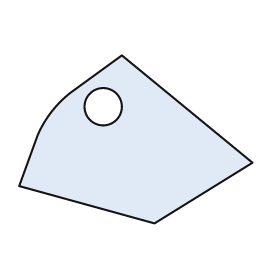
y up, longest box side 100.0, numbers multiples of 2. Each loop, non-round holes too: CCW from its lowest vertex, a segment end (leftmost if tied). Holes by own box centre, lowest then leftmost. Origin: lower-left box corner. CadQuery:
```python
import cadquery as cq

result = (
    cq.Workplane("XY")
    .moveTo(58.0, 0.0)
    .lineTo(100.0, 26.0)
    .lineTo(44.0, 72.0)
    .lineTo(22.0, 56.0)
    .threePointArc((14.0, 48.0), (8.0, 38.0))
    .lineTo(0.0, 16.0)
    .close()
    .moveTo(36.0, 50.0)
    .circle(8.0)
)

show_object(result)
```